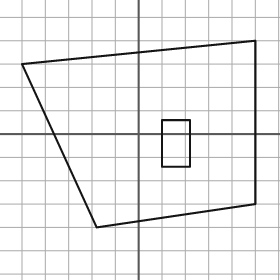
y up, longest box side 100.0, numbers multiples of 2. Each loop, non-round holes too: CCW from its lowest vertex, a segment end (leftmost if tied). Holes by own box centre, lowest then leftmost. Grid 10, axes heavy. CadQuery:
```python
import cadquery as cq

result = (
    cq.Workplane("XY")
    .moveTo(-18.0, -40.0)
    .lineTo(50.0, -30.0)
    .lineTo(50.0, 40.0)
    .lineTo(-50.0, 30.0)
    .close()
    .moveTo(10.0, -14.0)
    .lineTo(22.0, -14.0)
    .lineTo(22.0, 6.0)
    .lineTo(10.0, 6.0)
    .close()
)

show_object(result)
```